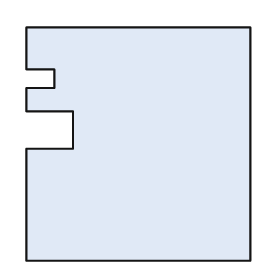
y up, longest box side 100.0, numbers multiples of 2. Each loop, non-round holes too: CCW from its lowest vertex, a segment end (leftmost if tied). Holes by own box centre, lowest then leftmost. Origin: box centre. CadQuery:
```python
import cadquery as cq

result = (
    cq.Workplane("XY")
    .moveTo(-48.0, -50.0)
    .lineTo(48.0, -50.0)
    .lineTo(48.0, 50.0)
    .lineTo(-48.0, 50.0)
    .lineTo(-48.0, 32.0)
    .lineTo(-36.0, 32.0)
    .lineTo(-36.0, 24.0)
    .lineTo(-48.0, 24.0)
    .lineTo(-48.0, 14.0)
    .lineTo(-28.0, 14.0)
    .lineTo(-28.0, -2.0)
    .lineTo(-48.0, -2.0)
    .close()
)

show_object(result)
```